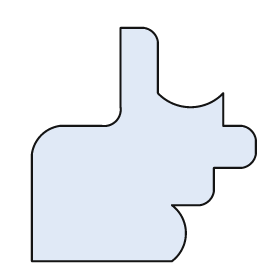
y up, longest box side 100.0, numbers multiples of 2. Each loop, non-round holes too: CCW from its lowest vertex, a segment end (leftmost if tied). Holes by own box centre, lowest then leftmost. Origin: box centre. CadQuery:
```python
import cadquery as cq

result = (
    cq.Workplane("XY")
    .moveTo(-48.0, -50.0)
    .lineTo(12.0, -50.0)
    .threePointArc((18.0, -38.0), (12.0, -26.0))
    .lineTo(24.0, -26.0)
    .threePointArc((28.0, -24.0), (30.0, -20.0))
    .lineTo(30.0, -10.0)
    .lineTo(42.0, -10.0)
    .threePointArc((46.0, -8.0), (48.0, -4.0))
    .lineTo(48.0, 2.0)
    .threePointArc((46.0, 6.0), (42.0, 8.0))
    .lineTo(34.0, 8.0)
    .lineTo(34.0, 22.0)
    .threePointArc((20.0, 16.0), (6.0, 22.0))
    .lineTo(6.0, 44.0)
    .threePointArc((4.0, 48.0), (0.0, 50.0))
    .lineTo(-10.0, 50.0)
    .lineTo(-10.0, 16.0)
    .threePointArc((-12.0, 10.0), (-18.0, 8.0))
    .lineTo(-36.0, 8.0)
    .threePointArc((-44.0, 4.0), (-48.0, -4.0))
    .close()
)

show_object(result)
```